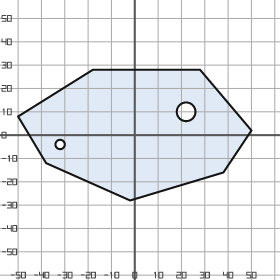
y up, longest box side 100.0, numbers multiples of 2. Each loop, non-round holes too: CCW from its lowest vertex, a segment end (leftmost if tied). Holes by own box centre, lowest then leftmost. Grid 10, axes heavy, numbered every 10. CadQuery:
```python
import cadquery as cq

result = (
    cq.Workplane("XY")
    .moveTo(-2.0, -28.0)
    .lineTo(38.0, -16.0)
    .lineTo(50.0, 2.0)
    .lineTo(28.0, 28.0)
    .lineTo(-18.0, 28.0)
    .lineTo(-50.0, 8.0)
    .lineTo(-38.0, -12.0)
    .close()
    .moveTo(-32.0, -4.0)
    .circle(2.0)
    .moveTo(22.0, 10.0)
    .circle(4.0)
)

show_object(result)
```